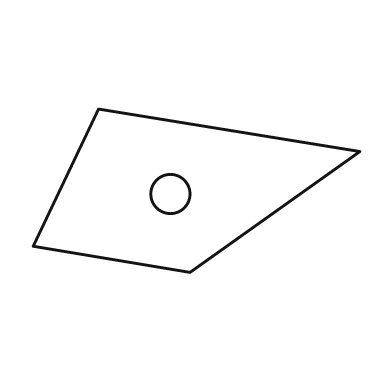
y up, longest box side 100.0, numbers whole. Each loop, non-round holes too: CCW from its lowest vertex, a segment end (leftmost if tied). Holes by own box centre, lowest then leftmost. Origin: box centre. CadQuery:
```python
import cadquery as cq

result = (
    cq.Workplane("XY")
    .moveTo(-2.0, -25.0)
    .lineTo(50.0, 12.0)
    .lineTo(-30.0, 25.0)
    .lineTo(-50.0, -17.0)
    .close()
    .moveTo(-8.0, -1.0)
    .circle(6.0)
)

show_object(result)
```